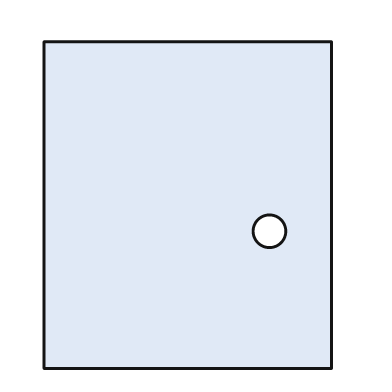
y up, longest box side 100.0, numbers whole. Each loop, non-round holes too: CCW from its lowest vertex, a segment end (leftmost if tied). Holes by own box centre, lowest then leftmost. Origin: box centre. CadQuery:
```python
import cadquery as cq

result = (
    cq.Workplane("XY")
    .moveTo(-44.0, -50.0)
    .lineTo(44.0, -50.0)
    .lineTo(44.0, 50.0)
    .lineTo(-44.0, 50.0)
    .close()
    .moveTo(25.0, -8.0)
    .circle(5.0)
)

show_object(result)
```